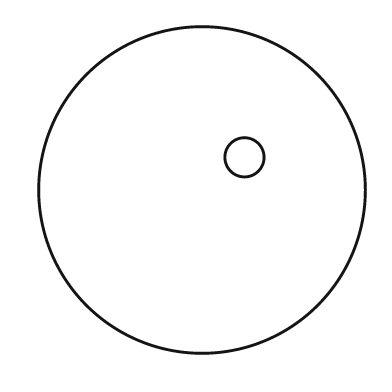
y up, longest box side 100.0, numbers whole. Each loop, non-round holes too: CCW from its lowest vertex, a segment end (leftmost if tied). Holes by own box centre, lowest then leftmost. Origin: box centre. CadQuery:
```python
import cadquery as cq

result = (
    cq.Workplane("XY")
    .moveTo(0.0, 0.0)
    .circle(50.0)
    .moveTo(13.0, 10.0)
    .circle(6.0)
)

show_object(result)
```